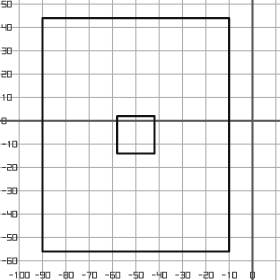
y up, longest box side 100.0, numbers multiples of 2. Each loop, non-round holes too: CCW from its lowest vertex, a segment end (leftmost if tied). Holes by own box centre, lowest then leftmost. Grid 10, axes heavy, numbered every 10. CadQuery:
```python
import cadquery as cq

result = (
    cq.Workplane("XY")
    .moveTo(-90.0, -56.0)
    .lineTo(-10.0, -56.0)
    .lineTo(-10.0, 44.0)
    .lineTo(-90.0, 44.0)
    .close()
    .moveTo(-58.0, -14.0)
    .lineTo(-42.0, -14.0)
    .lineTo(-42.0, 2.0)
    .lineTo(-58.0, 2.0)
    .close()
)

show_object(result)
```